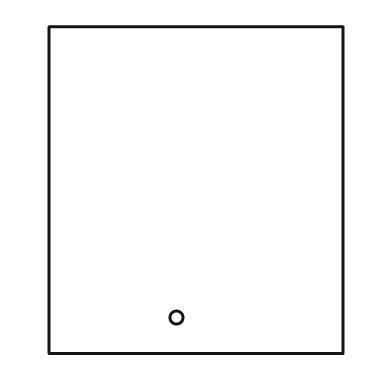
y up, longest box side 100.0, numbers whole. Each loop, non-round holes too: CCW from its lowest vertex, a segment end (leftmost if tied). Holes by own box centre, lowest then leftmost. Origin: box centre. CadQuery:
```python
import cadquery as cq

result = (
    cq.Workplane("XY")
    .moveTo(-45.0, -50.0)
    .lineTo(45.0, -50.0)
    .lineTo(45.0, 50.0)
    .lineTo(-45.0, 50.0)
    .close()
    .moveTo(-6.0, -39.0)
    .circle(2.0)
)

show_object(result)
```